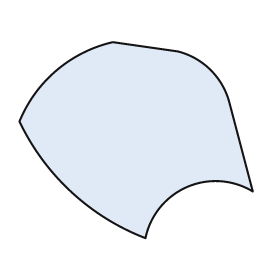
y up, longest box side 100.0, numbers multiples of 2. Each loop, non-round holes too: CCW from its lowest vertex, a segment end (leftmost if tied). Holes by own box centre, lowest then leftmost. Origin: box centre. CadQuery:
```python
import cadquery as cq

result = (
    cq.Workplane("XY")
    .moveTo(4.0, -42.0)
    .threePointArc((22.0, -20.0), (50.0, -22.0))
    .lineTo(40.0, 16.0)
    .threePointArc((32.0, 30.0), (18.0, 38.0))
    .lineTo(-10.0, 42.0)
    .threePointArc((-34.0, 30.0), (-50.0, 8.0))
    .threePointArc((-28.0, -22.0), (4.0, -42.0))
    .close()
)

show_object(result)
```